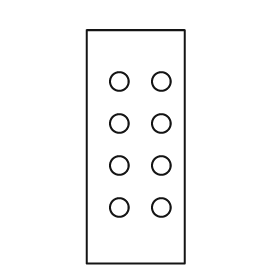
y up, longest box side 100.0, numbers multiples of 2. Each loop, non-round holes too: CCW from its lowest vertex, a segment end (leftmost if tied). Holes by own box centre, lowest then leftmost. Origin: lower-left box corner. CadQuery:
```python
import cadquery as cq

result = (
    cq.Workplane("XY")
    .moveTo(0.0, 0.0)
    .lineTo(42.0, 0.0)
    .lineTo(42.0, 100.0)
    .lineTo(0.0, 100.0)
    .close()
    .moveTo(14.0, 24.0)
    .circle(4.0)
    .moveTo(32.0, 24.0)
    .circle(4.0)
    .moveTo(14.0, 42.0)
    .circle(4.0)
    .moveTo(32.0, 42.0)
    .circle(4.0)
    .moveTo(14.0, 60.0)
    .circle(4.0)
    .moveTo(32.0, 60.0)
    .circle(4.0)
    .moveTo(14.0, 78.0)
    .circle(4.0)
    .moveTo(32.0, 78.0)
    .circle(4.0)
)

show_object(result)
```